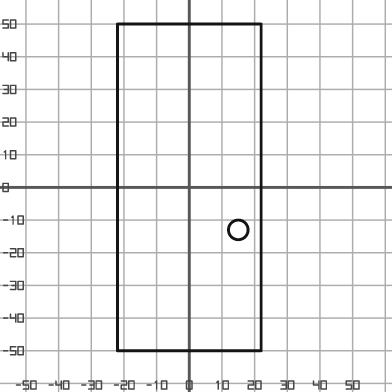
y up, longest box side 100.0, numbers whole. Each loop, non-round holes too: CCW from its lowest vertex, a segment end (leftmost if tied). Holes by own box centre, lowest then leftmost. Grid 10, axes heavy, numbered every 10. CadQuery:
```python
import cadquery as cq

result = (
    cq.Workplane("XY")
    .moveTo(-22.0, -50.0)
    .lineTo(22.0, -50.0)
    .lineTo(22.0, 50.0)
    .lineTo(-22.0, 50.0)
    .close()
    .moveTo(15.0, -13.0)
    .circle(3.0)
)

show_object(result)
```